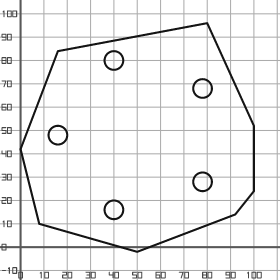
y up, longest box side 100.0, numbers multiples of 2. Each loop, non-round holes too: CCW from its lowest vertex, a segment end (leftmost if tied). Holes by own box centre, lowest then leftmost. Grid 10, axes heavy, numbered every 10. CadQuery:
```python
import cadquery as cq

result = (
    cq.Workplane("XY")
    .moveTo(50.0, -2.0)
    .lineTo(92.0, 14.0)
    .lineTo(100.0, 24.0)
    .lineTo(100.0, 52.0)
    .lineTo(80.0, 96.0)
    .lineTo(16.0, 84.0)
    .lineTo(0.0, 42.0)
    .lineTo(8.0, 10.0)
    .close()
    .moveTo(40.0, 16.0)
    .circle(4.0)
    .moveTo(78.0, 28.0)
    .circle(4.0)
    .moveTo(16.0, 48.0)
    .circle(4.0)
    .moveTo(78.0, 68.0)
    .circle(4.0)
    .moveTo(40.0, 80.0)
    .circle(4.0)
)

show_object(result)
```